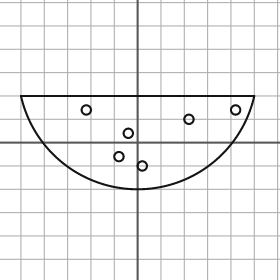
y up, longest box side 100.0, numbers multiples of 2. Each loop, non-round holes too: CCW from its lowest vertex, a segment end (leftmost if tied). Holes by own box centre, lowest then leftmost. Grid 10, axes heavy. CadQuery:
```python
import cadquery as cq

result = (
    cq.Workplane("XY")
    .moveTo(-50.0, 20.0)
    .threePointArc((0.0, -20.0), (50.0, 20.0))
    .close()
    .moveTo(2.0, -10.0)
    .circle(2.0)
    .moveTo(-8.0, -6.0)
    .circle(2.0)
    .moveTo(-4.0, 4.0)
    .circle(2.0)
    .moveTo(22.0, 10.0)
    .circle(2.0)
    .moveTo(-22.0, 14.0)
    .circle(2.0)
    .moveTo(42.0, 14.0)
    .circle(2.0)
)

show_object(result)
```